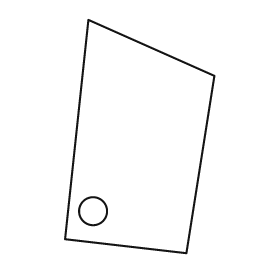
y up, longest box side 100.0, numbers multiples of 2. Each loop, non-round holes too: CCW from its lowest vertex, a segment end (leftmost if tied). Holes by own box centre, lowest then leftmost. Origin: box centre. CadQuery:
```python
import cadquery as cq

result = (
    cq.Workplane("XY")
    .moveTo(20.0, -50.0)
    .lineTo(32.0, 26.0)
    .lineTo(-22.0, 50.0)
    .lineTo(-32.0, -44.0)
    .close()
    .moveTo(-20.0, -32.0)
    .circle(6.0)
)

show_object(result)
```